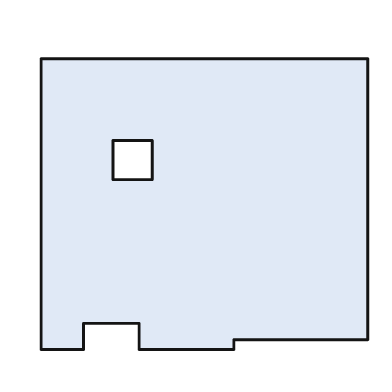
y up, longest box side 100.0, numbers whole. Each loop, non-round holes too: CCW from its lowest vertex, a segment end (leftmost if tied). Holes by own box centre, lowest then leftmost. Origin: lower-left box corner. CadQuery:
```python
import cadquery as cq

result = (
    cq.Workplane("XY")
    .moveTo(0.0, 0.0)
    .lineTo(13.0, 0.0)
    .lineTo(13.0, 8.0)
    .lineTo(30.0, 8.0)
    .lineTo(30.0, 0.0)
    .lineTo(59.0, 0.0)
    .lineTo(59.0, 3.0)
    .lineTo(100.0, 3.0)
    .lineTo(100.0, 89.0)
    .lineTo(0.0, 89.0)
    .close()
    .moveTo(22.0, 52.0)
    .lineTo(34.0, 52.0)
    .lineTo(34.0, 64.0)
    .lineTo(22.0, 64.0)
    .close()
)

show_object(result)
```